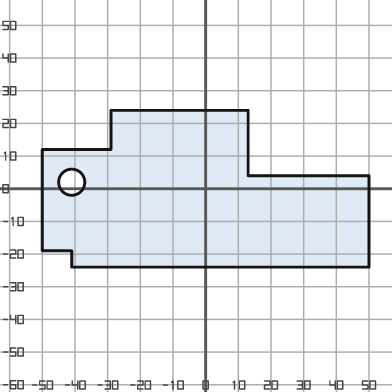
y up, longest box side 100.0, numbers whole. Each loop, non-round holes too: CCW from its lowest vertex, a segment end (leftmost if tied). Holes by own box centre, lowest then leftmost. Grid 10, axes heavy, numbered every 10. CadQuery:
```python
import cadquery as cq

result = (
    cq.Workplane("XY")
    .moveTo(-41.0, -24.0)
    .lineTo(50.0, -24.0)
    .lineTo(50.0, 4.0)
    .lineTo(13.0, 4.0)
    .lineTo(13.0, 24.0)
    .lineTo(-29.0, 24.0)
    .lineTo(-29.0, 12.0)
    .lineTo(-50.0, 12.0)
    .lineTo(-50.0, -19.0)
    .lineTo(-41.0, -19.0)
    .close()
    .moveTo(-41.0, 2.0)
    .circle(4.0)
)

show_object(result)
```